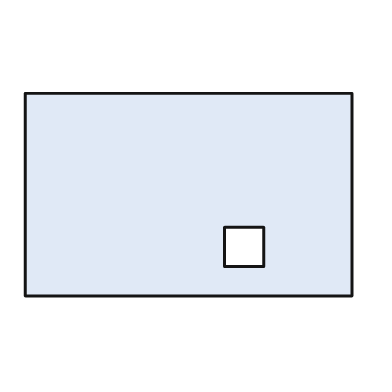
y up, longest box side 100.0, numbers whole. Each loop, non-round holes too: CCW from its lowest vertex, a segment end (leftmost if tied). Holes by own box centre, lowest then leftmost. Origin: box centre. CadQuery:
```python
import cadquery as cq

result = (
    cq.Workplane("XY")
    .moveTo(-50.0, -31.0)
    .lineTo(50.0, -31.0)
    .lineTo(50.0, 31.0)
    .lineTo(-50.0, 31.0)
    .close()
    .moveTo(11.0, -22.0)
    .lineTo(23.0, -22.0)
    .lineTo(23.0, -10.0)
    .lineTo(11.0, -10.0)
    .close()
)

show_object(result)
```